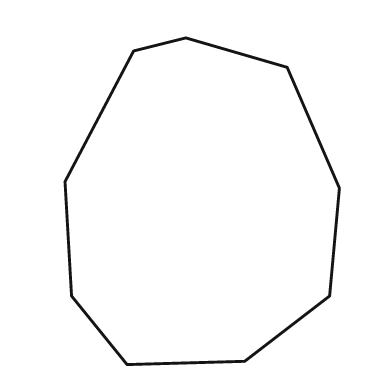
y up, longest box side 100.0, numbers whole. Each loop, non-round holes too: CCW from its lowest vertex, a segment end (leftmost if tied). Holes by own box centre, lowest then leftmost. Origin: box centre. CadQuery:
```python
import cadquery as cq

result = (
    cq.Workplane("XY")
    .moveTo(-23.0, -50.0)
    .lineTo(13.0, -49.0)
    .lineTo(39.0, -29.0)
    .lineTo(42.0, 4.0)
    .lineTo(26.0, 41.0)
    .lineTo(-5.0, 50.0)
    .lineTo(-21.0, 46.0)
    .lineTo(-42.0, 6.0)
    .lineTo(-40.0, -29.0)
    .close()
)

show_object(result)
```